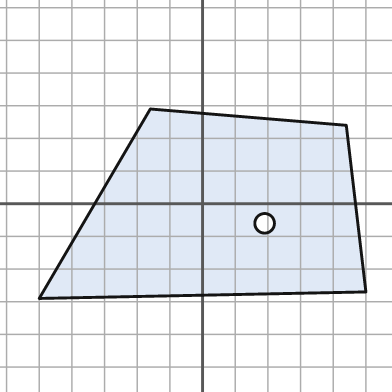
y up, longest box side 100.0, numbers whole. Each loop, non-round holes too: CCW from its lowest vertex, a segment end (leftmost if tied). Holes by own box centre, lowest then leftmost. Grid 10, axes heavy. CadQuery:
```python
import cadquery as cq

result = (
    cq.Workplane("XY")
    .moveTo(-50.0, -29.0)
    .lineTo(50.0, -27.0)
    .lineTo(44.0, 24.0)
    .lineTo(-16.0, 29.0)
    .close()
    .moveTo(19.0, -6.0)
    .circle(3.0)
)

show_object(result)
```